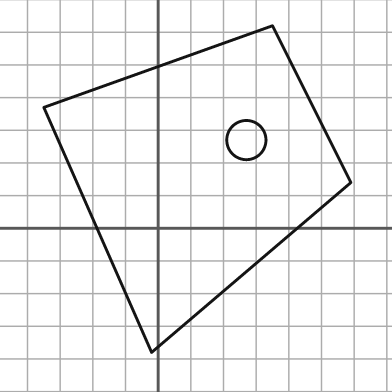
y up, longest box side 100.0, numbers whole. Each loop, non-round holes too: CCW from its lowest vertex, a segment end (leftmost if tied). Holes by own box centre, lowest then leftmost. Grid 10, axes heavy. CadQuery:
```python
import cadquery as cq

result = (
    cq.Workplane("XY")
    .moveTo(-2.0, -38.0)
    .lineTo(59.0, 14.0)
    .lineTo(35.0, 62.0)
    .lineTo(-35.0, 37.0)
    .close()
    .moveTo(27.0, 27.0)
    .circle(6.0)
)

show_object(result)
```